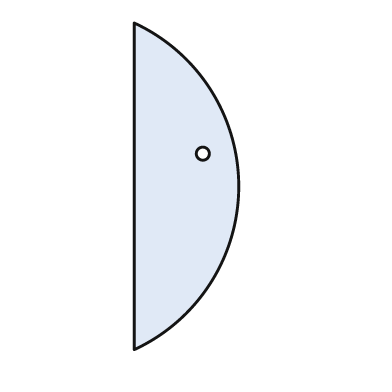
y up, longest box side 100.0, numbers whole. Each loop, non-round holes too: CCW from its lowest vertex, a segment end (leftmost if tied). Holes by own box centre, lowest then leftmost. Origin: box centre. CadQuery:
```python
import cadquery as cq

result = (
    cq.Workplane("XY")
    .moveTo(-16.0, -50.0)
    .threePointArc((16.0, 0.0), (-16.0, 50.0))
    .close()
    .moveTo(5.0, 10.0)
    .circle(2.0)
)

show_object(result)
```